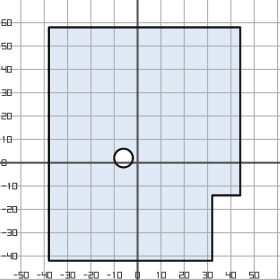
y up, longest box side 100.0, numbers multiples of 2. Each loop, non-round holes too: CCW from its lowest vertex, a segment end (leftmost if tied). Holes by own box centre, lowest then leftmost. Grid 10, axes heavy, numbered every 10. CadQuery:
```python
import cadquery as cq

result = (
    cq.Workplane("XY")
    .moveTo(-38.0, -42.0)
    .lineTo(32.0, -42.0)
    .lineTo(32.0, -14.0)
    .lineTo(44.0, -14.0)
    .lineTo(44.0, 58.0)
    .lineTo(-38.0, 58.0)
    .close()
    .moveTo(-6.0, 2.0)
    .circle(4.0)
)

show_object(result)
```